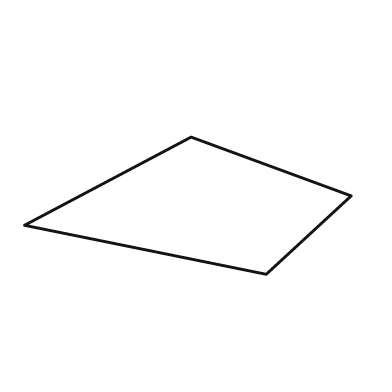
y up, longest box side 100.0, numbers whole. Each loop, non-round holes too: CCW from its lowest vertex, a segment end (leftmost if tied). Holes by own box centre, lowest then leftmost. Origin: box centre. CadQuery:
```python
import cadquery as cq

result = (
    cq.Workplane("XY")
    .moveTo(24.0, -21.0)
    .lineTo(50.0, 3.0)
    .lineTo(1.0, 21.0)
    .lineTo(-50.0, -6.0)
    .close()
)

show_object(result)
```